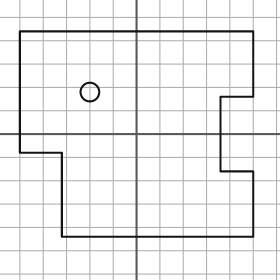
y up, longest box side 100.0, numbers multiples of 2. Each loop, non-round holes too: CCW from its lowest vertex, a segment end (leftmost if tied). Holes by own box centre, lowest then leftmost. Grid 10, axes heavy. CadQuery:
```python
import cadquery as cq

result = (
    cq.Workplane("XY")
    .moveTo(-32.0, -44.0)
    .lineTo(50.0, -44.0)
    .lineTo(50.0, -16.0)
    .lineTo(36.0, -16.0)
    .lineTo(36.0, 16.0)
    .lineTo(50.0, 16.0)
    .lineTo(50.0, 44.0)
    .lineTo(-50.0, 44.0)
    .lineTo(-50.0, -8.0)
    .lineTo(-32.0, -8.0)
    .close()
    .moveTo(-20.0, 18.0)
    .circle(4.0)
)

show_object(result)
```